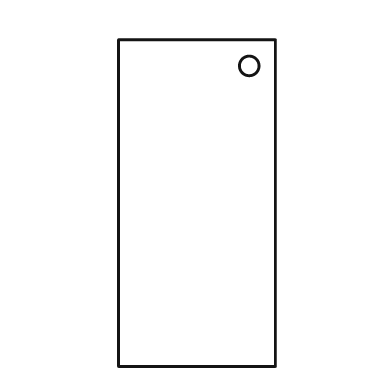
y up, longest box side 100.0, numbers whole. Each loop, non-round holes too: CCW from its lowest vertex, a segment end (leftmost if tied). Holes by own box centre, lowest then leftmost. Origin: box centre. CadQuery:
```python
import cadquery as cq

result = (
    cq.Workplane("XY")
    .moveTo(-24.0, -50.0)
    .lineTo(24.0, -50.0)
    .lineTo(24.0, 50.0)
    .lineTo(-24.0, 50.0)
    .close()
    .moveTo(16.0, 42.0)
    .circle(3.0)
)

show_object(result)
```